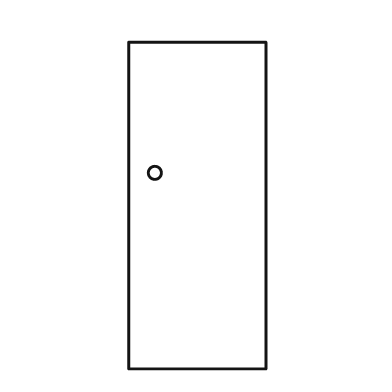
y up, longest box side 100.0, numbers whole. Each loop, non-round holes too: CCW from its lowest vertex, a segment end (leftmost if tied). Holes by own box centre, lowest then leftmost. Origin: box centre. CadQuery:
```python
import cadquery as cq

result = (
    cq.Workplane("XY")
    .moveTo(-21.0, -50.0)
    .lineTo(21.0, -50.0)
    .lineTo(21.0, 50.0)
    .lineTo(-21.0, 50.0)
    .close()
    .moveTo(-13.0, 10.0)
    .circle(2.0)
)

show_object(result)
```